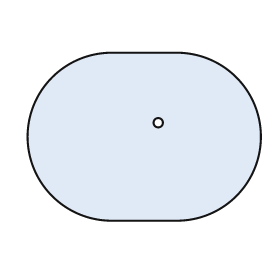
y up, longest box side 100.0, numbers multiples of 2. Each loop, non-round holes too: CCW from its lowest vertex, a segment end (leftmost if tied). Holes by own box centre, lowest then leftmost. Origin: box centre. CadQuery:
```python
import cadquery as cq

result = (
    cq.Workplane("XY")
    .moveTo(-14.0, -36.0)
    .lineTo(14.0, -36.0)
    .threePointArc((50.0, 0.0), (14.0, 36.0))
    .lineTo(-14.0, 36.0)
    .threePointArc((-50.0, 0.0), (-14.0, -36.0))
    .close()
    .moveTo(6.0, 6.0)
    .circle(2.0)
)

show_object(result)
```